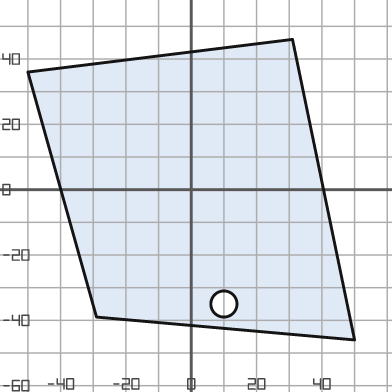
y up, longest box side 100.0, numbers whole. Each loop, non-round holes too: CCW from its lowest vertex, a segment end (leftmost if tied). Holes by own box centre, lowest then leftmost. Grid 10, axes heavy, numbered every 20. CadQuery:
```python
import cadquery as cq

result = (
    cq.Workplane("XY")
    .moveTo(50.0, -46.0)
    .lineTo(31.0, 46.0)
    .lineTo(-50.0, 36.0)
    .lineTo(-29.0, -39.0)
    .close()
    .moveTo(10.0, -35.0)
    .circle(4.0)
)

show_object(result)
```